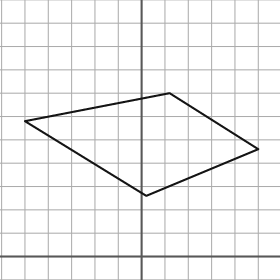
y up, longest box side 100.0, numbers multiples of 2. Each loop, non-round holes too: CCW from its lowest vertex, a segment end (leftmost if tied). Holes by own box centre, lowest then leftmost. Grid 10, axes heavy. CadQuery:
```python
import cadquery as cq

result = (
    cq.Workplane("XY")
    .moveTo(2.0, 26.0)
    .lineTo(50.0, 46.0)
    .lineTo(12.0, 70.0)
    .lineTo(-50.0, 58.0)
    .close()
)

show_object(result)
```